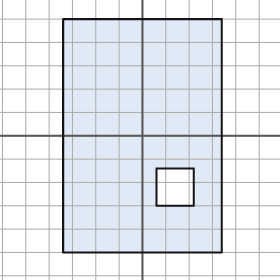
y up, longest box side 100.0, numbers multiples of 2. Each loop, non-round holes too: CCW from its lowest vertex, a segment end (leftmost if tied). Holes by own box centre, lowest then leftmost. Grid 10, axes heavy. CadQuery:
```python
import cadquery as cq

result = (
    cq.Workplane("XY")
    .moveTo(-34.0, -50.0)
    .lineTo(34.0, -50.0)
    .lineTo(34.0, 50.0)
    .lineTo(-34.0, 50.0)
    .close()
    .moveTo(6.0, -30.0)
    .lineTo(22.0, -30.0)
    .lineTo(22.0, -14.0)
    .lineTo(6.0, -14.0)
    .close()
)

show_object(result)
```